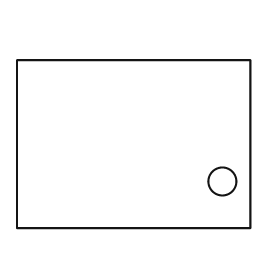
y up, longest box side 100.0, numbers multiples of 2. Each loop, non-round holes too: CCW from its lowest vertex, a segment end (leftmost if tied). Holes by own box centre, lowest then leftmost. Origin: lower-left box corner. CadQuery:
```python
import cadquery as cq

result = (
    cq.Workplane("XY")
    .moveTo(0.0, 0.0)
    .lineTo(100.0, 0.0)
    .lineTo(100.0, 72.0)
    .lineTo(0.0, 72.0)
    .close()
    .moveTo(88.0, 20.0)
    .circle(6.0)
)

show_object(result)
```